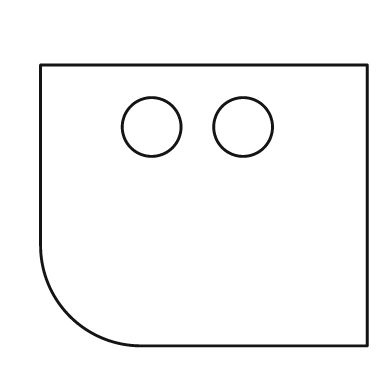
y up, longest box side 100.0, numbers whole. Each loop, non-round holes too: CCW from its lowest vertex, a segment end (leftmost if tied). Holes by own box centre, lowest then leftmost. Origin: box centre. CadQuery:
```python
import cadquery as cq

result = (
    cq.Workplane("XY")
    .moveTo(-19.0, -43.0)
    .lineTo(50.0, -43.0)
    .lineTo(50.0, 43.0)
    .lineTo(-50.0, 43.0)
    .lineTo(-50.0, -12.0)
    .threePointArc((-41.0, -34.0), (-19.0, -43.0))
    .close()
    .moveTo(-16.0, 24.0)
    .circle(9.0)
    .moveTo(12.0, 24.0)
    .circle(9.0)
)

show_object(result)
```